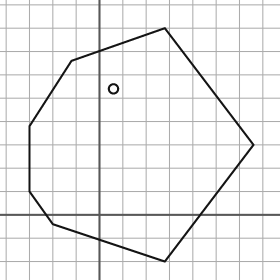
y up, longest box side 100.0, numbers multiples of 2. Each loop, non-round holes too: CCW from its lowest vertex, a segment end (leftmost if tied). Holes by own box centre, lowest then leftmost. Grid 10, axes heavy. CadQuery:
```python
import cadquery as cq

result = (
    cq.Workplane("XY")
    .moveTo(28.0, -20.0)
    .lineTo(66.0, 30.0)
    .lineTo(28.0, 80.0)
    .lineTo(-12.0, 66.0)
    .lineTo(-30.0, 38.0)
    .lineTo(-30.0, 10.0)
    .lineTo(-20.0, -4.0)
    .close()
    .moveTo(6.0, 54.0)
    .circle(2.0)
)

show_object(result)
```